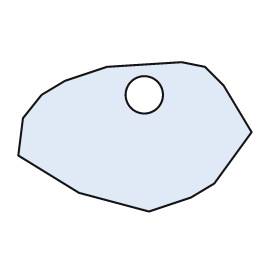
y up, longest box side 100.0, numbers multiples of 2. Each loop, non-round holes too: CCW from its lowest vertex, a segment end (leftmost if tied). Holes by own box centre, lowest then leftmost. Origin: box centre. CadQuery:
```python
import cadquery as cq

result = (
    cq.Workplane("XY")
    .moveTo(6.0, -32.0)
    .lineTo(24.0, -26.0)
    .lineTo(34.0, -20.0)
    .lineTo(50.0, 2.0)
    .lineTo(38.0, 22.0)
    .lineTo(30.0, 30.0)
    .lineTo(20.0, 32.0)
    .lineTo(-12.0, 30.0)
    .lineTo(-30.0, 24.0)
    .lineTo(-40.0, 18.0)
    .lineTo(-48.0, 8.0)
    .lineTo(-50.0, -8.0)
    .lineTo(-24.0, -24.0)
    .close()
    .moveTo(4.0, 18.0)
    .circle(8.0)
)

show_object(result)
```